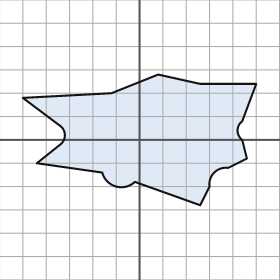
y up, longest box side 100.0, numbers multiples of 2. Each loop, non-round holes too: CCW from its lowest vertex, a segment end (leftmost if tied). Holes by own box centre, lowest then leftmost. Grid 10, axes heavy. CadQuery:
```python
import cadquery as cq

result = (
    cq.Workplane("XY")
    .moveTo(26.0, -28.0)
    .lineTo(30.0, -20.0)
    .threePointArc((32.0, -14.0), (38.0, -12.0))
    .lineTo(46.0, -8.0)
    .lineTo(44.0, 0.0)
    .threePointArc((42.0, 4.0), (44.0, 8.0))
    .lineTo(50.0, 24.0)
    .lineTo(26.0, 24.0)
    .lineTo(8.0, 28.0)
    .lineTo(-12.0, 20.0)
    .lineTo(-50.0, 18.0)
    .lineTo(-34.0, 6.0)
    .threePointArc((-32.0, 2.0), (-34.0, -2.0))
    .lineTo(-44.0, -10.0)
    .lineTo(-16.0, -14.0)
    .threePointArc((-10.0, -20.0), (-2.0, -18.0))
    .close()
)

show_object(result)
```